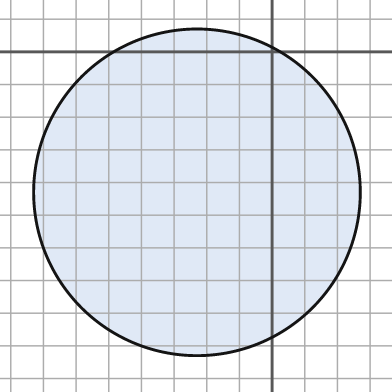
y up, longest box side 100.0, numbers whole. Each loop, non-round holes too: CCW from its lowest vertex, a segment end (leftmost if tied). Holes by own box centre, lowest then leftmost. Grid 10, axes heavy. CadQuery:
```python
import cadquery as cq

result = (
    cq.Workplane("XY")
    .moveTo(-23.0, -43.0)
    .circle(50.0)
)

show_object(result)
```